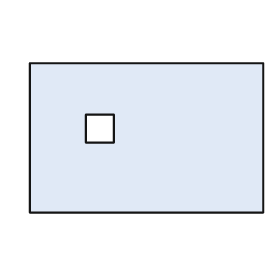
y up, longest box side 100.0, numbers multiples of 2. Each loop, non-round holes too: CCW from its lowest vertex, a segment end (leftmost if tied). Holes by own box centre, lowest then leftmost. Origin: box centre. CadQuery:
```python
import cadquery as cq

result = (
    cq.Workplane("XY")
    .moveTo(-50.0, -32.0)
    .lineTo(50.0, -32.0)
    .lineTo(50.0, 32.0)
    .lineTo(-50.0, 32.0)
    .close()
    .moveTo(-26.0, -2.0)
    .lineTo(-14.0, -2.0)
    .lineTo(-14.0, 10.0)
    .lineTo(-26.0, 10.0)
    .close()
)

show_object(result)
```